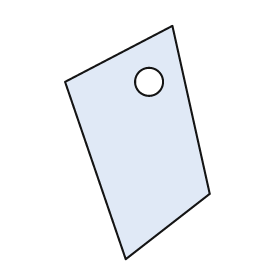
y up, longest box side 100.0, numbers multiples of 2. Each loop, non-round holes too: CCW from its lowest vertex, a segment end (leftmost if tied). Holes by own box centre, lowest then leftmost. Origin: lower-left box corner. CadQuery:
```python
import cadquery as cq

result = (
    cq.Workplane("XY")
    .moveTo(26.0, 0.0)
    .lineTo(62.0, 28.0)
    .lineTo(46.0, 100.0)
    .lineTo(0.0, 76.0)
    .close()
    .moveTo(36.0, 76.0)
    .circle(6.0)
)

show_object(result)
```